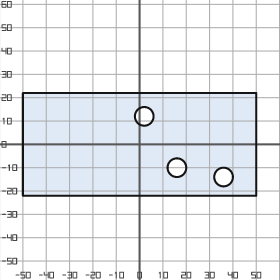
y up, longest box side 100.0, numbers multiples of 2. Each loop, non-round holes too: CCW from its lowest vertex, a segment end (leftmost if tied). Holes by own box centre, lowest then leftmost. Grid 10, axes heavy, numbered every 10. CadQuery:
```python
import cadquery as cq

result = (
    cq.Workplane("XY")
    .moveTo(-50.0, -22.0)
    .lineTo(50.0, -22.0)
    .lineTo(50.0, 22.0)
    .lineTo(-50.0, 22.0)
    .close()
    .moveTo(36.0, -14.0)
    .circle(4.0)
    .moveTo(16.0, -10.0)
    .circle(4.0)
    .moveTo(2.0, 12.0)
    .circle(4.0)
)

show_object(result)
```